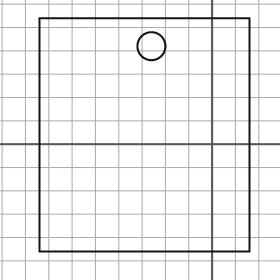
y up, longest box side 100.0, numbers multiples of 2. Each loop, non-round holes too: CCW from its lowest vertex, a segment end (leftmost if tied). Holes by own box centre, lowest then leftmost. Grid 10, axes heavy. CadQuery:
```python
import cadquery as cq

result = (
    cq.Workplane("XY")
    .moveTo(-74.0, -46.0)
    .lineTo(16.0, -46.0)
    .lineTo(16.0, 54.0)
    .lineTo(-74.0, 54.0)
    .close()
    .moveTo(-26.0, 42.0)
    .circle(6.0)
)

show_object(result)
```